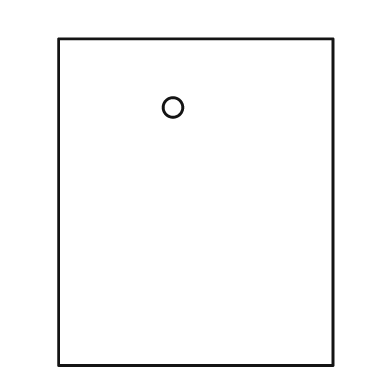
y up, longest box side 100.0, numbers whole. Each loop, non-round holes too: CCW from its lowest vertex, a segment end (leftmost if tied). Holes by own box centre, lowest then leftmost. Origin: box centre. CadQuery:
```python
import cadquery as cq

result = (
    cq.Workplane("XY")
    .moveTo(-42.0, -50.0)
    .lineTo(42.0, -50.0)
    .lineTo(42.0, 50.0)
    .lineTo(-42.0, 50.0)
    .close()
    .moveTo(-7.0, 29.0)
    .circle(3.0)
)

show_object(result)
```